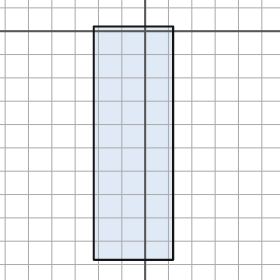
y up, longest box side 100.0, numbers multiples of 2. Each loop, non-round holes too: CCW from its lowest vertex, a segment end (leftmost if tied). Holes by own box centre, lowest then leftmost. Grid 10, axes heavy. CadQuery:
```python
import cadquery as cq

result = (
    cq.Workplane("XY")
    .moveTo(-22.0, -98.0)
    .lineTo(12.0, -98.0)
    .lineTo(12.0, 2.0)
    .lineTo(-22.0, 2.0)
    .close()
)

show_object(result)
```